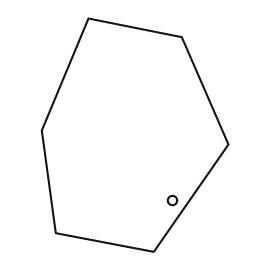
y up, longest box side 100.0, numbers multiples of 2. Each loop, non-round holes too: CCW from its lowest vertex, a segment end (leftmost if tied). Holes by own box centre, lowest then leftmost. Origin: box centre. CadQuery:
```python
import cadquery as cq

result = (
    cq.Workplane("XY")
    .moveTo(8.0, -50.0)
    .lineTo(40.0, -4.0)
    .lineTo(20.0, 42.0)
    .lineTo(-20.0, 50.0)
    .lineTo(-40.0, 2.0)
    .lineTo(-34.0, -42.0)
    .close()
    .moveTo(16.0, -28.0)
    .circle(2.0)
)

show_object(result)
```